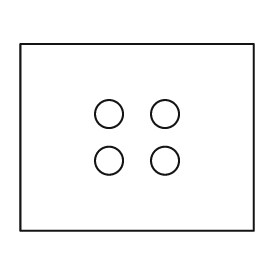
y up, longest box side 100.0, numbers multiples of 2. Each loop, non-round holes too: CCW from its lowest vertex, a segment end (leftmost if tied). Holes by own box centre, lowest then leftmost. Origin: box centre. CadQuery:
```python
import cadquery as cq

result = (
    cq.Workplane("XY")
    .moveTo(-50.0, -40.0)
    .lineTo(50.0, -40.0)
    .lineTo(50.0, 40.0)
    .lineTo(-50.0, 40.0)
    .close()
    .moveTo(-12.0, -10.0)
    .circle(6.0)
    .moveTo(12.0, -10.0)
    .circle(6.0)
    .moveTo(-12.0, 10.0)
    .circle(6.0)
    .moveTo(12.0, 10.0)
    .circle(6.0)
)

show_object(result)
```